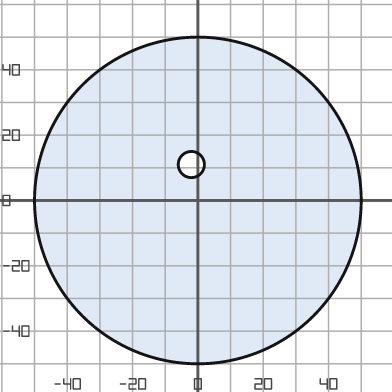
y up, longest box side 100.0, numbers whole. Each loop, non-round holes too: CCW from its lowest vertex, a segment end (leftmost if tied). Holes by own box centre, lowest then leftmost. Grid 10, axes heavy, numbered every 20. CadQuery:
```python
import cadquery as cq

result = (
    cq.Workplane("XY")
    .moveTo(0.0, 0.0)
    .circle(50.0)
    .moveTo(-2.0, 11.0)
    .circle(4.0)
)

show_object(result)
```